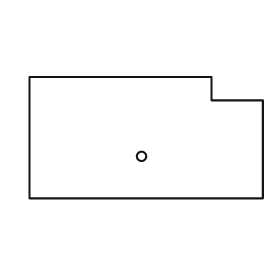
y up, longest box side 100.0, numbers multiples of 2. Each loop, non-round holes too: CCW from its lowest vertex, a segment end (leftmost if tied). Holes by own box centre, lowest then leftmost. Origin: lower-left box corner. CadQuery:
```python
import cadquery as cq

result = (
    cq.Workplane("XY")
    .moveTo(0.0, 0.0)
    .lineTo(100.0, 0.0)
    .lineTo(100.0, 42.0)
    .lineTo(78.0, 42.0)
    .lineTo(78.0, 52.0)
    .lineTo(0.0, 52.0)
    .close()
    .moveTo(48.0, 18.0)
    .circle(2.0)
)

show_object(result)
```